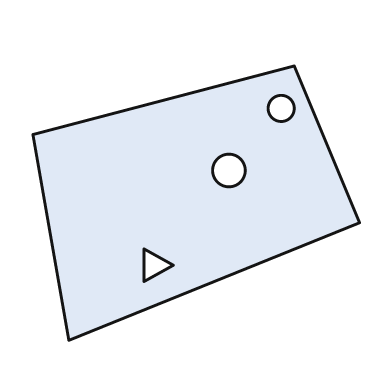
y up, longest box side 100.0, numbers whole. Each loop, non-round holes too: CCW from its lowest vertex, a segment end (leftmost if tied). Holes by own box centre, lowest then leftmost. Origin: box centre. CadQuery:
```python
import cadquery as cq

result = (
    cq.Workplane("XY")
    .moveTo(-39.0, -42.0)
    .lineTo(50.0, -6.0)
    .lineTo(30.0, 42.0)
    .lineTo(-50.0, 21.0)
    .close()
    .moveTo(-16.0, -24.0)
    .lineTo(-7.0, -19.0)
    .lineTo(-16.0, -14.0)
    .close()
    .moveTo(10.0, 10.0)
    .circle(5.0)
    .moveTo(26.0, 29.0)
    .circle(4.0)
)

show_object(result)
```